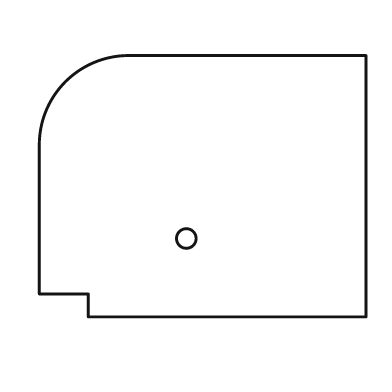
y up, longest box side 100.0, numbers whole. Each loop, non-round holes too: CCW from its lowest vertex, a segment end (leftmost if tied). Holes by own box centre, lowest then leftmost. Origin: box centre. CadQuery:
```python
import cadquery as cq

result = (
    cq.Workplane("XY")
    .moveTo(-35.0, -40.0)
    .lineTo(50.0, -40.0)
    .lineTo(50.0, 40.0)
    .lineTo(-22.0, 40.0)
    .threePointArc((-42.0, 32.0), (-50.0, 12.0))
    .lineTo(-50.0, -33.0)
    .lineTo(-35.0, -33.0)
    .close()
    .moveTo(-5.0, -16.0)
    .circle(3.0)
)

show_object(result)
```